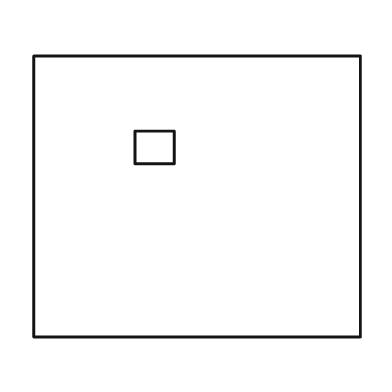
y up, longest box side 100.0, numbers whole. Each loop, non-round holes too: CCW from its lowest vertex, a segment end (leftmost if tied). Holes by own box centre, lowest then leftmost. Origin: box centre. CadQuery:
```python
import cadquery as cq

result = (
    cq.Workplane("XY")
    .moveTo(-50.0, -43.0)
    .lineTo(50.0, -43.0)
    .lineTo(50.0, 43.0)
    .lineTo(-50.0, 43.0)
    .close()
    .moveTo(-19.0, 10.0)
    .lineTo(-7.0, 10.0)
    .lineTo(-7.0, 20.0)
    .lineTo(-19.0, 20.0)
    .close()
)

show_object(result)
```